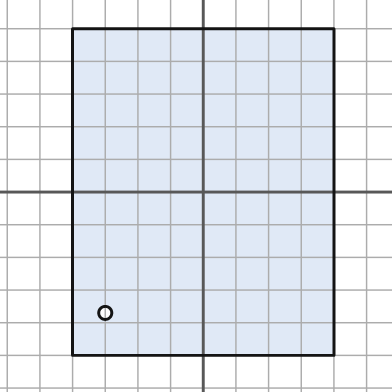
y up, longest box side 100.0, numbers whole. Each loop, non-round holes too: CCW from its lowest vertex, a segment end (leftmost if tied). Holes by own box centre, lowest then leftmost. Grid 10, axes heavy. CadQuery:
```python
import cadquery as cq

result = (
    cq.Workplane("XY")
    .moveTo(-40.0, -50.0)
    .lineTo(40.0, -50.0)
    .lineTo(40.0, 50.0)
    .lineTo(-40.0, 50.0)
    .close()
    .moveTo(-30.0, -37.0)
    .circle(2.0)
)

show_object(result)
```